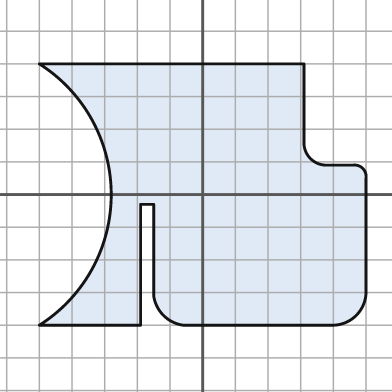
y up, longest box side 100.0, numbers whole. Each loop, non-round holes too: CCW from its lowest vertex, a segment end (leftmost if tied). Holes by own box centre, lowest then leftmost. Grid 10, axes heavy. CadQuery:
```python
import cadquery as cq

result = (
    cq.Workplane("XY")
    .moveTo(-50.0, -40.0)
    .lineTo(-19.0, -40.0)
    .lineTo(-19.0, -3.0)
    .lineTo(-15.0, -3.0)
    .lineTo(-15.0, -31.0)
    .threePointArc((-12.0, -37.0), (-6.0, -40.0))
    .lineTo(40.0, -40.0)
    .threePointArc((47.0, -37.0), (50.0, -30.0))
    .lineTo(50.0, 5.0)
    .threePointArc((49.0, 8.0), (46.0, 9.0))
    .lineTo(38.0, 9.0)
    .threePointArc((33.0, 11.0), (31.0, 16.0))
    .lineTo(31.0, 40.0)
    .lineTo(-50.0, 40.0)
    .threePointArc((-28.0, 0.0), (-50.0, -40.0))
    .close()
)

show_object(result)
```